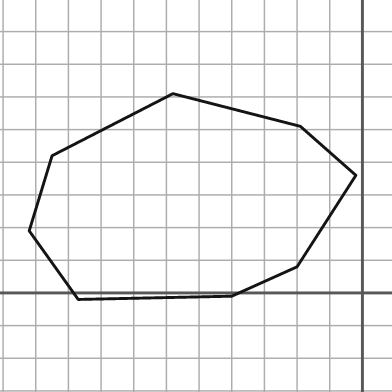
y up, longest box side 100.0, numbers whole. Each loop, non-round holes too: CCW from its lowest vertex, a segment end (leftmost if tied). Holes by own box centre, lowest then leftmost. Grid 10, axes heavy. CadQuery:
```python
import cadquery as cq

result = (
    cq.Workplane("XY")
    .moveTo(-87.0, -2.0)
    .lineTo(-40.0, -1.0)
    .lineTo(-20.0, 8.0)
    .lineTo(-2.0, 36.0)
    .lineTo(-19.0, 51.0)
    .lineTo(-58.0, 61.0)
    .lineTo(-95.0, 42.0)
    .lineTo(-102.0, 19.0)
    .close()
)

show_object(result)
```